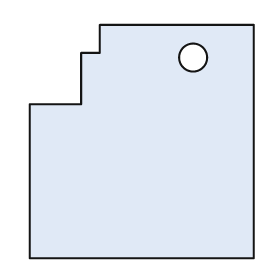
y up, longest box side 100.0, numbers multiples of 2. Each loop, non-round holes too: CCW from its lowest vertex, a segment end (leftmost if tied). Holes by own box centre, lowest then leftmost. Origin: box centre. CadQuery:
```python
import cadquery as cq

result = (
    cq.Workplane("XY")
    .moveTo(-48.0, -50.0)
    .lineTo(48.0, -50.0)
    .lineTo(48.0, 50.0)
    .lineTo(-18.0, 50.0)
    .lineTo(-18.0, 38.0)
    .lineTo(-26.0, 38.0)
    .lineTo(-26.0, 16.0)
    .lineTo(-48.0, 16.0)
    .close()
    .moveTo(22.0, 36.0)
    .circle(6.0)
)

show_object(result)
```